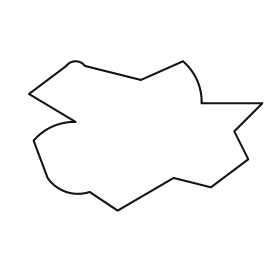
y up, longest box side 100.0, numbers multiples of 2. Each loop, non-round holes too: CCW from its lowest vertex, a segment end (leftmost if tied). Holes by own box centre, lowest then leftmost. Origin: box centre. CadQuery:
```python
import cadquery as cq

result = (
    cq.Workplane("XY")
    .moveTo(-12.0, -32.0)
    .lineTo(12.0, -18.0)
    .lineTo(28.0, -22.0)
    .lineTo(44.0, -10.0)
    .lineTo(38.0, 2.0)
    .lineTo(50.0, 14.0)
    .lineTo(24.0, 14.0)
    .threePointArc((22.0, 24.0), (16.0, 32.0))
    .lineTo(-2.0, 24.0)
    .lineTo(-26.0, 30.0)
    .threePointArc((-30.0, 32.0), (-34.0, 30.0))
    .lineTo(-50.0, 18.0)
    .lineTo(-30.0, 6.0)
    .threePointArc((-40.0, 4.0), (-48.0, -2.0))
    .lineTo(-42.0, -18.0)
    .threePointArc((-34.0, -24.0), (-24.0, -24.0))
    .close()
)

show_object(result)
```